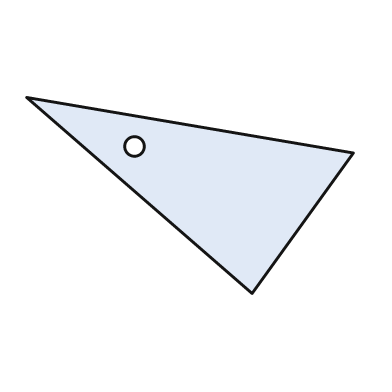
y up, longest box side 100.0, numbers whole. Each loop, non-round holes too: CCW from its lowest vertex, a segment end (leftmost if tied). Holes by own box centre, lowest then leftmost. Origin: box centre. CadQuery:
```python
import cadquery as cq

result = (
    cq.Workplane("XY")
    .moveTo(19.0, -30.0)
    .lineTo(50.0, 13.0)
    .lineTo(-50.0, 30.0)
    .close()
    .moveTo(-17.0, 15.0)
    .circle(3.0)
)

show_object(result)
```